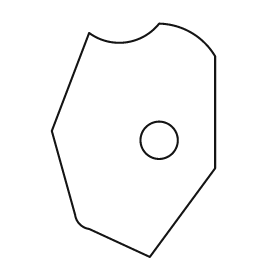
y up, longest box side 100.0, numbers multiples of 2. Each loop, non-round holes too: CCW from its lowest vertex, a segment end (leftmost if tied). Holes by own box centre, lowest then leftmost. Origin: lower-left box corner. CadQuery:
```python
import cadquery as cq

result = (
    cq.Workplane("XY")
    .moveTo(42.0, 0.0)
    .lineTo(70.0, 38.0)
    .lineTo(70.0, 86.0)
    .threePointArc((60.0, 96.0), (46.0, 100.0))
    .threePointArc((32.0, 92.0), (16.0, 96.0))
    .lineTo(0.0, 54.0)
    .lineTo(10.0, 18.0)
    .threePointArc((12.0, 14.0), (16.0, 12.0))
    .close()
    .moveTo(46.0, 50.0)
    .circle(8.0)
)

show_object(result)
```